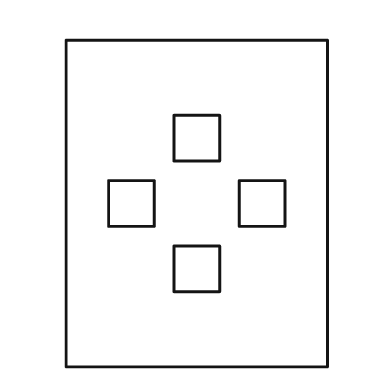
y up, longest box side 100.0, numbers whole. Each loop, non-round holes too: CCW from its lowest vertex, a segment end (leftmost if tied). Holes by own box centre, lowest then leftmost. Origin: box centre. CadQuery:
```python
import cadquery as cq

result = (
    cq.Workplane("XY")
    .moveTo(-40.0, -50.0)
    .lineTo(40.0, -50.0)
    .lineTo(40.0, 50.0)
    .lineTo(-40.0, 50.0)
    .close()
    .moveTo(-7.0, -27.0)
    .lineTo(7.0, -27.0)
    .lineTo(7.0, -13.0)
    .lineTo(-7.0, -13.0)
    .close()
    .moveTo(-27.0, -7.0)
    .lineTo(-13.0, -7.0)
    .lineTo(-13.0, 7.0)
    .lineTo(-27.0, 7.0)
    .close()
    .moveTo(13.0, -7.0)
    .lineTo(27.0, -7.0)
    .lineTo(27.0, 7.0)
    .lineTo(13.0, 7.0)
    .close()
    .moveTo(-7.0, 13.0)
    .lineTo(7.0, 13.0)
    .lineTo(7.0, 27.0)
    .lineTo(-7.0, 27.0)
    .close()
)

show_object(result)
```